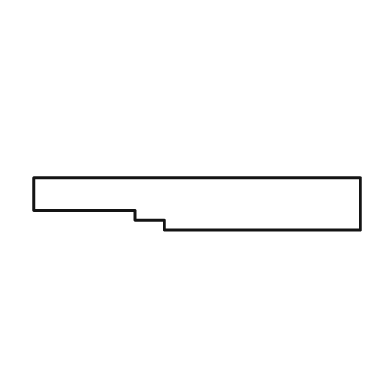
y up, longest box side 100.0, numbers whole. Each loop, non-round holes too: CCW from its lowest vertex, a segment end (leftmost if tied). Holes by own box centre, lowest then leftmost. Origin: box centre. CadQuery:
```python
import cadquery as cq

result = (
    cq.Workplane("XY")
    .moveTo(-10.0, -8.0)
    .lineTo(50.0, -8.0)
    .lineTo(50.0, 8.0)
    .lineTo(-50.0, 8.0)
    .lineTo(-50.0, -2.0)
    .lineTo(-19.0, -2.0)
    .lineTo(-19.0, -5.0)
    .lineTo(-10.0, -5.0)
    .close()
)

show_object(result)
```